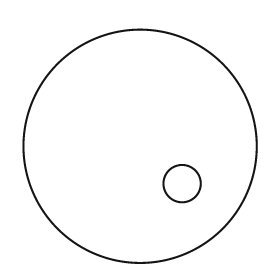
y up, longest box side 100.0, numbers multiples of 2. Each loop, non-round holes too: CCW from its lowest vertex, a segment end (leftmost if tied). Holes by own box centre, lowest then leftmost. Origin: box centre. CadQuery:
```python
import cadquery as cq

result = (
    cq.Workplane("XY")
    .moveTo(0.0, 0.0)
    .circle(50.0)
    .moveTo(18.0, -16.0)
    .circle(8.0)
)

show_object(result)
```